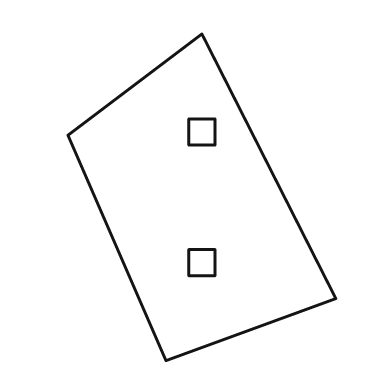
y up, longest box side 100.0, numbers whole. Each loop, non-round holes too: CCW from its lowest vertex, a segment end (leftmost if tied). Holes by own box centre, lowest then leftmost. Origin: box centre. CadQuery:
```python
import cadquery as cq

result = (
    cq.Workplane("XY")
    .moveTo(-11.0, -50.0)
    .lineTo(41.0, -31.0)
    .lineTo(0.0, 50.0)
    .lineTo(-41.0, 19.0)
    .close()
    .moveTo(-4.0, -24.0)
    .lineTo(4.0, -24.0)
    .lineTo(4.0, -16.0)
    .lineTo(-4.0, -16.0)
    .close()
    .moveTo(-4.0, 16.0)
    .lineTo(4.0, 16.0)
    .lineTo(4.0, 24.0)
    .lineTo(-4.0, 24.0)
    .close()
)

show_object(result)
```